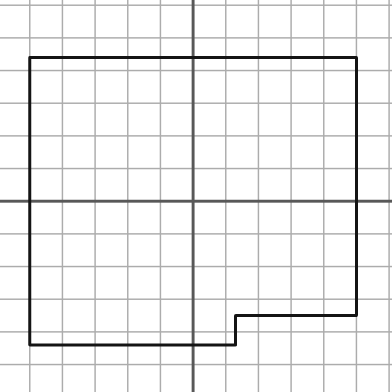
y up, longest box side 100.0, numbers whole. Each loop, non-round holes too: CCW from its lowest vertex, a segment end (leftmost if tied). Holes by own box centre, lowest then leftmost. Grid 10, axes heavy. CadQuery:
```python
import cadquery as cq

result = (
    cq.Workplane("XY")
    .moveTo(-50.0, -44.0)
    .lineTo(13.0, -44.0)
    .lineTo(13.0, -35.0)
    .lineTo(50.0, -35.0)
    .lineTo(50.0, 44.0)
    .lineTo(-50.0, 44.0)
    .close()
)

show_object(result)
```